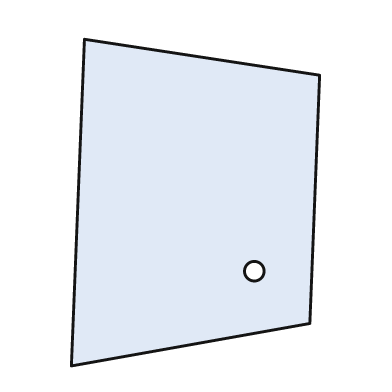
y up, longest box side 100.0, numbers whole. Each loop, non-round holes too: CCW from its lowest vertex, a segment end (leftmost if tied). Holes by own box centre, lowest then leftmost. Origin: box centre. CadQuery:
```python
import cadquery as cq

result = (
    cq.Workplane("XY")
    .moveTo(-38.0, -50.0)
    .lineTo(35.0, -37.0)
    .lineTo(38.0, 39.0)
    .lineTo(-34.0, 50.0)
    .close()
    .moveTo(18.0, -21.0)
    .circle(3.0)
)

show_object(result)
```